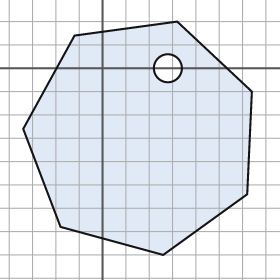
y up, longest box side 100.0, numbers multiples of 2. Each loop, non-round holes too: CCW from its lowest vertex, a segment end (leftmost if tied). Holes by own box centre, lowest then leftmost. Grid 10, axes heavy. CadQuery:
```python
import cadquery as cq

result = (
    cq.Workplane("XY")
    .moveTo(26.0, -80.0)
    .lineTo(62.0, -54.0)
    .lineTo(64.0, -10.0)
    .lineTo(32.0, 20.0)
    .lineTo(-12.0, 14.0)
    .lineTo(-34.0, -26.0)
    .lineTo(-18.0, -68.0)
    .close()
    .moveTo(28.0, 0.0)
    .circle(6.0)
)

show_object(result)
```